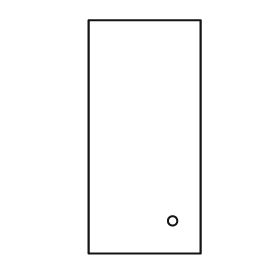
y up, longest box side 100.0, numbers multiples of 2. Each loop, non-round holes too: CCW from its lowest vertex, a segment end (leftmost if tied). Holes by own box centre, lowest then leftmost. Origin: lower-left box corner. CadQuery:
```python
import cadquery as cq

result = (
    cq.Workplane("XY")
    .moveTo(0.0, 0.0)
    .lineTo(48.0, 0.0)
    .lineTo(48.0, 100.0)
    .lineTo(0.0, 100.0)
    .close()
    .moveTo(36.0, 14.0)
    .circle(2.0)
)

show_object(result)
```